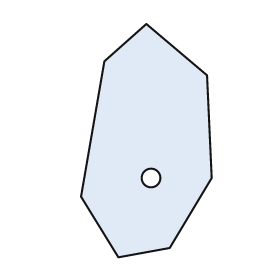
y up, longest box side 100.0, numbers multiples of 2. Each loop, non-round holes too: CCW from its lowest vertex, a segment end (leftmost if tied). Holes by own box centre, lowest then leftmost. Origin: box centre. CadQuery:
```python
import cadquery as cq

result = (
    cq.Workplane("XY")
    .moveTo(-12.0, -50.0)
    .lineTo(10.0, -46.0)
    .lineTo(28.0, -16.0)
    .lineTo(26.0, 28.0)
    .lineTo(0.0, 50.0)
    .lineTo(-18.0, 34.0)
    .lineTo(-28.0, -24.0)
    .close()
    .moveTo(2.0, -16.0)
    .circle(4.0)
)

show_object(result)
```